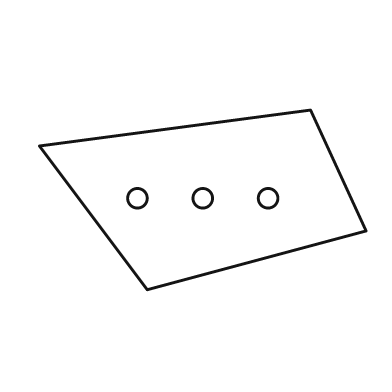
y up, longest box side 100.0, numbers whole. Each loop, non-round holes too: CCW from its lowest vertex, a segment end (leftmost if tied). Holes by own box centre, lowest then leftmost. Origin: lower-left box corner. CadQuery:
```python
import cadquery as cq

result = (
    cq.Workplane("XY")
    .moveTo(33.0, 0.0)
    .lineTo(100.0, 18.0)
    .lineTo(83.0, 55.0)
    .lineTo(0.0, 44.0)
    .close()
    .moveTo(30.0, 28.0)
    .circle(3.0)
    .moveTo(50.0, 28.0)
    .circle(3.0)
    .moveTo(70.0, 28.0)
    .circle(3.0)
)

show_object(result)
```